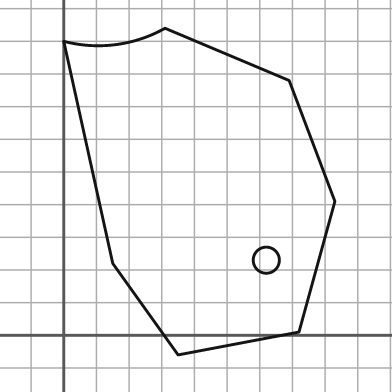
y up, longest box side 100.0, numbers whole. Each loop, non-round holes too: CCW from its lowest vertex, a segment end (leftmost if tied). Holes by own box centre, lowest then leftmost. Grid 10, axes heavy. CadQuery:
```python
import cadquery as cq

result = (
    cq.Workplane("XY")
    .moveTo(35.0, -6.0)
    .lineTo(72.0, 1.0)
    .lineTo(83.0, 41.0)
    .lineTo(69.0, 78.0)
    .lineTo(31.0, 94.0)
    .threePointArc((16.0, 89.0), (0.0, 90.0))
    .lineTo(15.0, 22.0)
    .close()
    .moveTo(62.0, 23.0)
    .circle(4.0)
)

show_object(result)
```